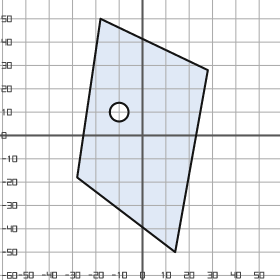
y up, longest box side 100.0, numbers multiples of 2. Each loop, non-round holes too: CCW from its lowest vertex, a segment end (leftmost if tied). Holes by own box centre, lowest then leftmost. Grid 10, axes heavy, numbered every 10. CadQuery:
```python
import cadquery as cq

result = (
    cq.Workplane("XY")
    .moveTo(14.0, -50.0)
    .lineTo(28.0, 28.0)
    .lineTo(-18.0, 50.0)
    .lineTo(-28.0, -18.0)
    .close()
    .moveTo(-10.0, 10.0)
    .circle(4.0)
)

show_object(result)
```